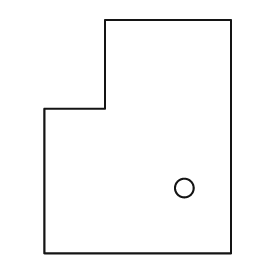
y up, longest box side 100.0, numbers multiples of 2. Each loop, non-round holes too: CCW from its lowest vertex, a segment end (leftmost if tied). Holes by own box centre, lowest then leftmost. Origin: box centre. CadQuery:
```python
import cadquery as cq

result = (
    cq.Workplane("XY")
    .moveTo(-40.0, -50.0)
    .lineTo(40.0, -50.0)
    .lineTo(40.0, 50.0)
    .lineTo(-14.0, 50.0)
    .lineTo(-14.0, 12.0)
    .lineTo(-40.0, 12.0)
    .close()
    .moveTo(20.0, -22.0)
    .circle(4.0)
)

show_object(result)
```